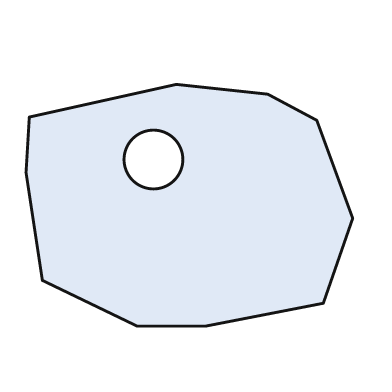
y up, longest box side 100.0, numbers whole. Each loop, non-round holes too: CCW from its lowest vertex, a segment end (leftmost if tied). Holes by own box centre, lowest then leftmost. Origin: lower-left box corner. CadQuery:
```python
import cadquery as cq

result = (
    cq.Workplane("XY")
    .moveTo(34.0, 0.0)
    .lineTo(55.0, 0.0)
    .lineTo(91.0, 7.0)
    .lineTo(100.0, 33.0)
    .lineTo(89.0, 63.0)
    .lineTo(74.0, 71.0)
    .lineTo(46.0, 74.0)
    .lineTo(1.0, 64.0)
    .lineTo(0.0, 47.0)
    .lineTo(5.0, 14.0)
    .close()
    .moveTo(39.0, 51.0)
    .circle(9.0)
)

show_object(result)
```